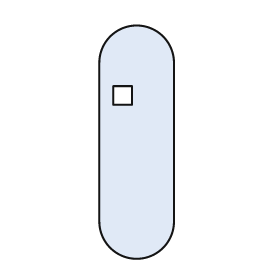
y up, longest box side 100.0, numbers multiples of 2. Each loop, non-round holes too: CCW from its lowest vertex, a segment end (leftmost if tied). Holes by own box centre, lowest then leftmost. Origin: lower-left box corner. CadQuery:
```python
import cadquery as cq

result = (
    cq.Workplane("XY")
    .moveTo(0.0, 16.0)
    .threePointArc((16.0, 0.0), (32.0, 16.0))
    .lineTo(32.0, 84.0)
    .threePointArc((16.0, 100.0), (0.0, 84.0))
    .close()
    .moveTo(6.0, 66.0)
    .lineTo(14.0, 66.0)
    .lineTo(14.0, 74.0)
    .lineTo(6.0, 74.0)
    .close()
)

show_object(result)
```